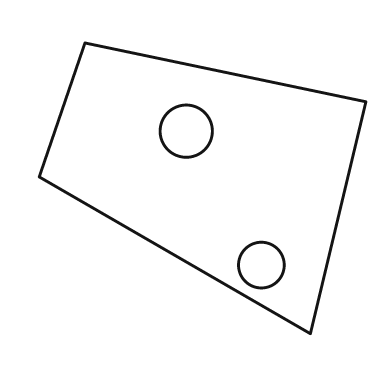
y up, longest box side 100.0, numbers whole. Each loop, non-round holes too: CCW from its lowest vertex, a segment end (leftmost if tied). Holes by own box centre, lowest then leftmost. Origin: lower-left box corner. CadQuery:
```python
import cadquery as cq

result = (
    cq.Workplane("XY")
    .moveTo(83.0, 0.0)
    .lineTo(100.0, 71.0)
    .lineTo(14.0, 89.0)
    .lineTo(0.0, 48.0)
    .close()
    .moveTo(68.0, 21.0)
    .circle(7.0)
    .moveTo(45.0, 62.0)
    .circle(8.0)
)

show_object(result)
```